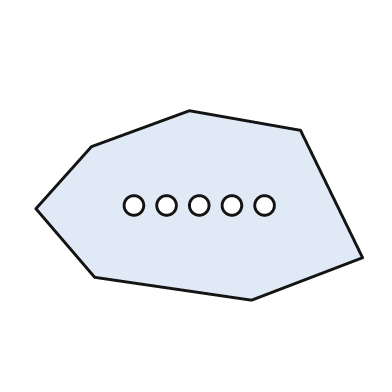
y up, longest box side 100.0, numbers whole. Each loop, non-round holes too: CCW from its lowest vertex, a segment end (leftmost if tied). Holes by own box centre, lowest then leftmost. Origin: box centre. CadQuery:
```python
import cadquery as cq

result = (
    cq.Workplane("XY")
    .moveTo(16.0, -29.0)
    .lineTo(50.0, -16.0)
    .lineTo(31.0, 23.0)
    .lineTo(-3.0, 29.0)
    .lineTo(-33.0, 18.0)
    .lineTo(-50.0, -1.0)
    .lineTo(-32.0, -22.0)
    .close()
    .moveTo(-20.0, 0.0)
    .circle(3.0)
    .moveTo(-10.0, 0.0)
    .circle(3.0)
    .moveTo(0.0, 0.0)
    .circle(3.0)
    .moveTo(10.0, 0.0)
    .circle(3.0)
    .moveTo(20.0, 0.0)
    .circle(3.0)
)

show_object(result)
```